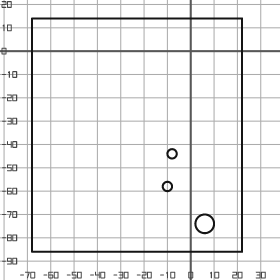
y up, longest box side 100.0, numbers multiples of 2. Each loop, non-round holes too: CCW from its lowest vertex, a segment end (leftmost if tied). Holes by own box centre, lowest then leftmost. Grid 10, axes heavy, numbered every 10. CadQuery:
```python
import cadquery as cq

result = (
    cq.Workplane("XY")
    .moveTo(-68.0, -86.0)
    .lineTo(22.0, -86.0)
    .lineTo(22.0, 14.0)
    .lineTo(-68.0, 14.0)
    .close()
    .moveTo(6.0, -74.0)
    .circle(4.0)
    .moveTo(-10.0, -58.0)
    .circle(2.0)
    .moveTo(-8.0, -44.0)
    .circle(2.0)
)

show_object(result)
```